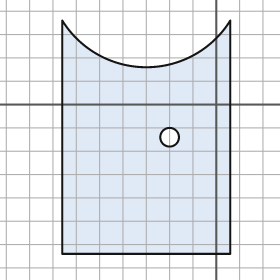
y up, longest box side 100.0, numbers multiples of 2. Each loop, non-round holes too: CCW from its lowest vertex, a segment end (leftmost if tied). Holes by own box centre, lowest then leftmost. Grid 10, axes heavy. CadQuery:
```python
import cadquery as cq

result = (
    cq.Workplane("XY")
    .moveTo(-66.0, -64.0)
    .lineTo(6.0, -64.0)
    .lineTo(6.0, 36.0)
    .threePointArc((-30.0, 16.0), (-66.0, 36.0))
    .close()
    .moveTo(-20.0, -14.0)
    .circle(4.0)
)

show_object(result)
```